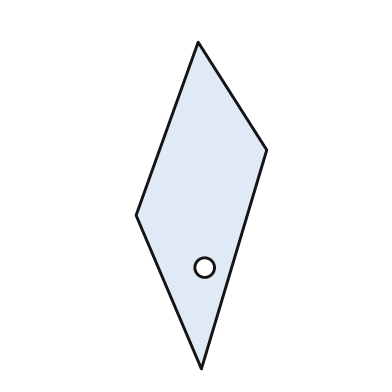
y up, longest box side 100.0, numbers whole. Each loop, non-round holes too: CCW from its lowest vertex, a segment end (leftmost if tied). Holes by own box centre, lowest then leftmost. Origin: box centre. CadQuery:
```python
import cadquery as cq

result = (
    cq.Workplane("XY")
    .moveTo(0.0, -50.0)
    .lineTo(20.0, 17.0)
    .lineTo(-1.0, 50.0)
    .lineTo(-20.0, -3.0)
    .close()
    .moveTo(1.0, -19.0)
    .circle(3.0)
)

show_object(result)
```